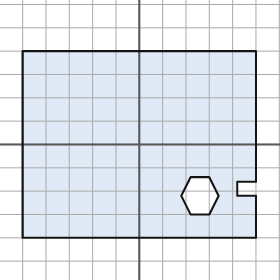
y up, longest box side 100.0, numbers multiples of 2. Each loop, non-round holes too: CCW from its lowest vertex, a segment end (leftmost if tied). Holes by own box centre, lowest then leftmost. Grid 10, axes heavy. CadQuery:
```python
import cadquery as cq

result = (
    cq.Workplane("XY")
    .moveTo(-50.0, -40.0)
    .lineTo(50.0, -40.0)
    .lineTo(50.0, -22.0)
    .lineTo(42.0, -22.0)
    .lineTo(42.0, -16.0)
    .lineTo(50.0, -16.0)
    .lineTo(50.0, 40.0)
    .lineTo(-50.0, 40.0)
    .close()
    .moveTo(22.0, -30.0)
    .lineTo(30.0, -30.0)
    .lineTo(34.0, -22.0)
    .lineTo(30.0, -14.0)
    .lineTo(22.0, -14.0)
    .lineTo(18.0, -22.0)
    .close()
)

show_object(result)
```